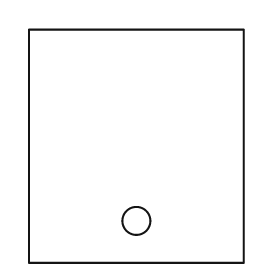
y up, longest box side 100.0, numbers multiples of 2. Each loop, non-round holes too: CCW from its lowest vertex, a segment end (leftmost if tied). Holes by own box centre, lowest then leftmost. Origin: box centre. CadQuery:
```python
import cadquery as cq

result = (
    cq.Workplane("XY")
    .moveTo(-46.0, -50.0)
    .lineTo(46.0, -50.0)
    .lineTo(46.0, 50.0)
    .lineTo(-46.0, 50.0)
    .close()
    .moveTo(0.0, -32.0)
    .circle(6.0)
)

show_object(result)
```